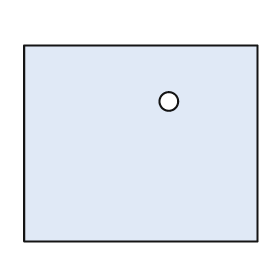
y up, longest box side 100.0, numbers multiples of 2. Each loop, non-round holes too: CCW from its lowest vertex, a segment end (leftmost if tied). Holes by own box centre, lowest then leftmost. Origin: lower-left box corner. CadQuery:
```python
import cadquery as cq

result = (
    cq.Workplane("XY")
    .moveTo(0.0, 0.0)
    .lineTo(100.0, 0.0)
    .lineTo(100.0, 84.0)
    .lineTo(0.0, 84.0)
    .close()
    .moveTo(62.0, 60.0)
    .circle(4.0)
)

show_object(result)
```